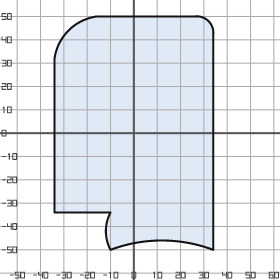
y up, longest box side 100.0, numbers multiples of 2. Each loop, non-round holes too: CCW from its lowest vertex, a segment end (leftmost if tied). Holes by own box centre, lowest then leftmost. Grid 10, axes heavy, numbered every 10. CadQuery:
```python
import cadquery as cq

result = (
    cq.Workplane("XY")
    .moveTo(-10.0, -50.0)
    .threePointArc((12.0, -46.0), (34.0, -50.0))
    .lineTo(34.0, 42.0)
    .threePointArc((32.0, 48.0), (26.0, 50.0))
    .lineTo(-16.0, 50.0)
    .threePointArc((-28.0, 44.0), (-34.0, 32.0))
    .lineTo(-34.0, -34.0)
    .lineTo(-10.0, -34.0)
    .threePointArc((-12.0, -42.0), (-10.0, -50.0))
    .close()
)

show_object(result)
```